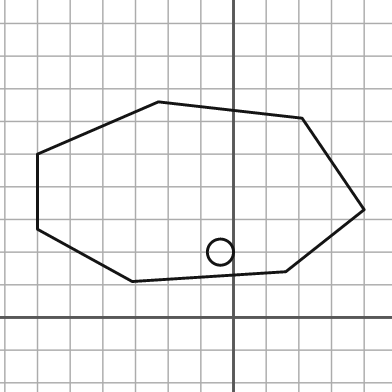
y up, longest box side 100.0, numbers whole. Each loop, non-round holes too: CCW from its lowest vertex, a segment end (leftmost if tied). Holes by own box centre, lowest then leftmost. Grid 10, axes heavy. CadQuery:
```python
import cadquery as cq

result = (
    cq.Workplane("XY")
    .moveTo(-31.0, 11.0)
    .lineTo(16.0, 14.0)
    .lineTo(40.0, 33.0)
    .lineTo(21.0, 61.0)
    .lineTo(-23.0, 66.0)
    .lineTo(-60.0, 50.0)
    .lineTo(-60.0, 27.0)
    .close()
    .moveTo(-4.0, 20.0)
    .circle(4.0)
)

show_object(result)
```